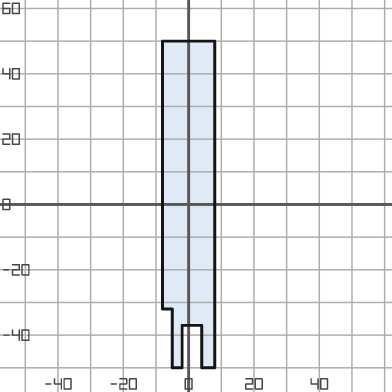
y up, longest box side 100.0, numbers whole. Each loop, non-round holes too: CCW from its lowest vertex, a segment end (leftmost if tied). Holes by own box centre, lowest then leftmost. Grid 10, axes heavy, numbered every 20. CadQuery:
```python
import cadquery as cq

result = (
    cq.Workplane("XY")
    .moveTo(-5.0, -50.0)
    .lineTo(-2.0, -50.0)
    .lineTo(-2.0, -37.0)
    .lineTo(4.0, -37.0)
    .lineTo(4.0, -50.0)
    .lineTo(8.0, -50.0)
    .lineTo(8.0, 50.0)
    .lineTo(-8.0, 50.0)
    .lineTo(-8.0, -32.0)
    .lineTo(-5.0, -32.0)
    .close()
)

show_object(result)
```